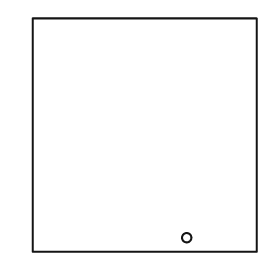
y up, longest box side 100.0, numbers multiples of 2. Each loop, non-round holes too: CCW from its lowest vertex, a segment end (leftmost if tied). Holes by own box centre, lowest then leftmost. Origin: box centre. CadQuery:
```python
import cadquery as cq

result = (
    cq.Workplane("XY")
    .moveTo(-48.0, -50.0)
    .lineTo(48.0, -50.0)
    .lineTo(48.0, 50.0)
    .lineTo(-48.0, 50.0)
    .close()
    .moveTo(18.0, -44.0)
    .circle(2.0)
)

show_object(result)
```